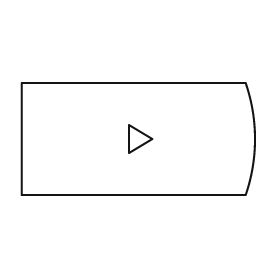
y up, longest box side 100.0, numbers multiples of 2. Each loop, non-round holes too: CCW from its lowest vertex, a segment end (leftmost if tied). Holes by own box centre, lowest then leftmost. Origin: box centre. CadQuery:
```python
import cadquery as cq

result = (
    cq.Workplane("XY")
    .moveTo(-50.0, -24.0)
    .lineTo(46.0, -24.0)
    .threePointArc((50.0, 0.0), (46.0, 24.0))
    .lineTo(-50.0, 24.0)
    .close()
    .moveTo(-4.0, -6.0)
    .lineTo(6.0, 0.0)
    .lineTo(-4.0, 6.0)
    .close()
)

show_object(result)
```